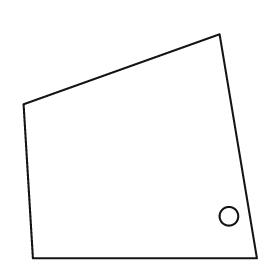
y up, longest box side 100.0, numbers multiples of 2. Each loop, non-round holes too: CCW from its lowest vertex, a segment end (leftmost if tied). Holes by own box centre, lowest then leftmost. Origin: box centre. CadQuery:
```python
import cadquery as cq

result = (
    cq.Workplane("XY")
    .moveTo(-46.0, -48.0)
    .lineTo(50.0, -48.0)
    .lineTo(34.0, 48.0)
    .lineTo(-50.0, 18.0)
    .close()
    .moveTo(38.0, -30.0)
    .circle(4.0)
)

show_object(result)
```